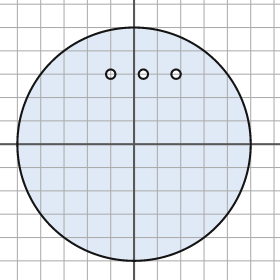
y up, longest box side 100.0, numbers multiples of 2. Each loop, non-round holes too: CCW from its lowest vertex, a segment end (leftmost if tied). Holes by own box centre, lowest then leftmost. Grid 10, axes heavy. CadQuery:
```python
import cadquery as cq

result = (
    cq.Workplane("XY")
    .moveTo(0.0, 0.0)
    .circle(50.0)
    .moveTo(-10.0, 30.0)
    .circle(2.0)
    .moveTo(4.0, 30.0)
    .circle(2.0)
    .moveTo(18.0, 30.0)
    .circle(2.0)
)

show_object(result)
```